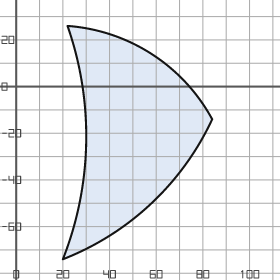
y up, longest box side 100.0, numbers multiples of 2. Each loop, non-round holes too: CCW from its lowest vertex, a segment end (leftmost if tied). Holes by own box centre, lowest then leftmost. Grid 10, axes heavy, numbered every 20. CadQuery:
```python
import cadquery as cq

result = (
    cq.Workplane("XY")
    .moveTo(20.0, -74.0)
    .threePointArc((58.0, -50.0), (84.0, -14.0))
    .threePointArc((58.0, 14.0), (22.0, 26.0))
    .threePointArc((30.0, -24.0), (20.0, -74.0))
    .close()
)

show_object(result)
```